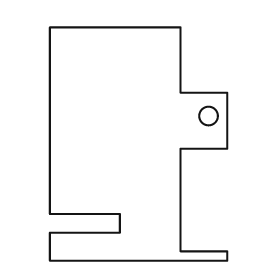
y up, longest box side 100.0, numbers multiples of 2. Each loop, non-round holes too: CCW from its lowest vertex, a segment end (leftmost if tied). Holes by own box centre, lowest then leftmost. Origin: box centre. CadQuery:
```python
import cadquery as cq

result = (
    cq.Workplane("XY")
    .moveTo(-38.0, -50.0)
    .lineTo(38.0, -50.0)
    .lineTo(38.0, -46.0)
    .lineTo(18.0, -46.0)
    .lineTo(18.0, -2.0)
    .lineTo(38.0, -2.0)
    .lineTo(38.0, 22.0)
    .lineTo(18.0, 22.0)
    .lineTo(18.0, 50.0)
    .lineTo(-38.0, 50.0)
    .lineTo(-38.0, -30.0)
    .lineTo(-8.0, -30.0)
    .lineTo(-8.0, -38.0)
    .lineTo(-38.0, -38.0)
    .close()
    .moveTo(30.0, 12.0)
    .circle(4.0)
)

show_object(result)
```